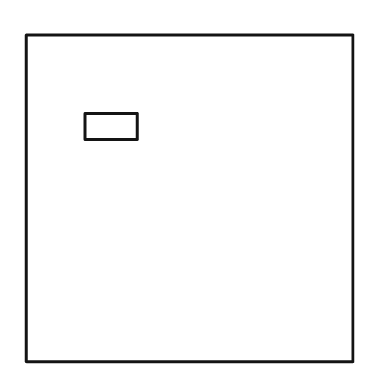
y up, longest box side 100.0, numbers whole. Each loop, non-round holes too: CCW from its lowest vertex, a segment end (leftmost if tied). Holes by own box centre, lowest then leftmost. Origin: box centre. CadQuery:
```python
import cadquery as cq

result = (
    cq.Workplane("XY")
    .moveTo(-50.0, -50.0)
    .lineTo(50.0, -50.0)
    .lineTo(50.0, 50.0)
    .lineTo(-50.0, 50.0)
    .close()
    .moveTo(-32.0, 18.0)
    .lineTo(-16.0, 18.0)
    .lineTo(-16.0, 26.0)
    .lineTo(-32.0, 26.0)
    .close()
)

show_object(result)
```